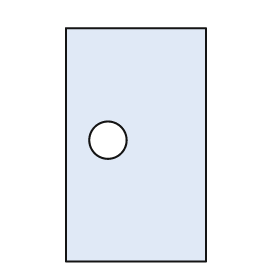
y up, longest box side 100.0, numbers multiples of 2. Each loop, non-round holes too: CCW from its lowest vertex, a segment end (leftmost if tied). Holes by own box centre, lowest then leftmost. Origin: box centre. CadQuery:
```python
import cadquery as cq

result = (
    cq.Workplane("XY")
    .moveTo(-30.0, -50.0)
    .lineTo(30.0, -50.0)
    .lineTo(30.0, 50.0)
    .lineTo(-30.0, 50.0)
    .close()
    .moveTo(-12.0, 2.0)
    .circle(8.0)
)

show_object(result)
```